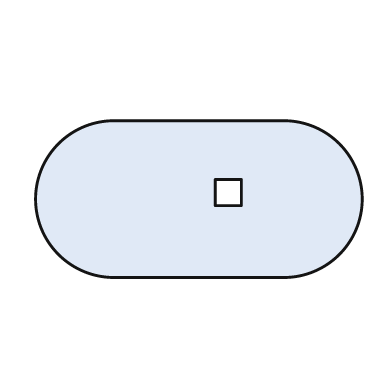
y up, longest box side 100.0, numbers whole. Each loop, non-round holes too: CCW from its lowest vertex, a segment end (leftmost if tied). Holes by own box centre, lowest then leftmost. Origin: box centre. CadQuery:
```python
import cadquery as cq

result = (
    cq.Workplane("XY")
    .moveTo(-26.0, -24.0)
    .lineTo(26.0, -24.0)
    .threePointArc((50.0, 0.0), (26.0, 24.0))
    .lineTo(-26.0, 24.0)
    .threePointArc((-50.0, 0.0), (-26.0, -24.0))
    .close()
    .moveTo(5.0, -2.0)
    .lineTo(13.0, -2.0)
    .lineTo(13.0, 6.0)
    .lineTo(5.0, 6.0)
    .close()
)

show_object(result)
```